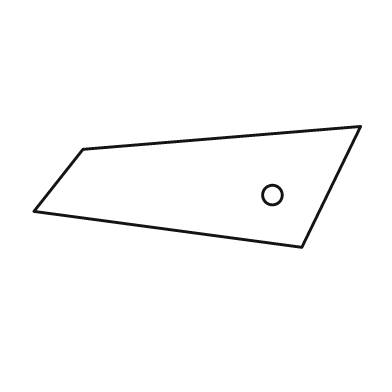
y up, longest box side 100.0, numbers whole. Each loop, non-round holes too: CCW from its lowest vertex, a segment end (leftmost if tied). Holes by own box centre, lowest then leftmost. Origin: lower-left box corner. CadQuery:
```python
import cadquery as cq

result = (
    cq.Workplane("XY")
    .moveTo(82.0, 0.0)
    .lineTo(100.0, 37.0)
    .lineTo(15.0, 30.0)
    .lineTo(0.0, 11.0)
    .close()
    .moveTo(73.0, 16.0)
    .circle(3.0)
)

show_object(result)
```